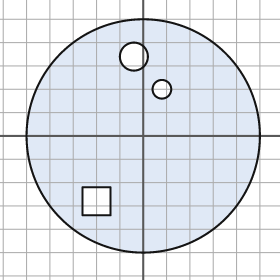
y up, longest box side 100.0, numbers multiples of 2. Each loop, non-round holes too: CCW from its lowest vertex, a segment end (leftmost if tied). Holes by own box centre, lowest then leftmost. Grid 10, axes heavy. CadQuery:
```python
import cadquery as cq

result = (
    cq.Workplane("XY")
    .moveTo(0.0, 0.0)
    .circle(50.0)
    .moveTo(-26.0, -34.0)
    .lineTo(-14.0, -34.0)
    .lineTo(-14.0, -22.0)
    .lineTo(-26.0, -22.0)
    .close()
    .moveTo(8.0, 20.0)
    .circle(4.0)
    .moveTo(-4.0, 34.0)
    .circle(6.0)
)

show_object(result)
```